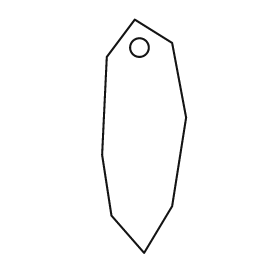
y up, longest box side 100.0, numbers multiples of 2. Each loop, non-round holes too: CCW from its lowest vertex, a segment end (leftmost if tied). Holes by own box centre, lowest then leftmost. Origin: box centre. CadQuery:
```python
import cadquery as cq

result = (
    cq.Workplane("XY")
    .moveTo(0.0, -50.0)
    .lineTo(12.0, -30.0)
    .lineTo(18.0, 8.0)
    .lineTo(12.0, 40.0)
    .lineTo(-4.0, 50.0)
    .lineTo(-16.0, 34.0)
    .lineTo(-18.0, -8.0)
    .lineTo(-14.0, -34.0)
    .close()
    .moveTo(-2.0, 38.0)
    .circle(4.0)
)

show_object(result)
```